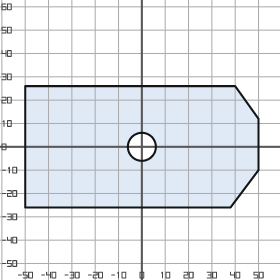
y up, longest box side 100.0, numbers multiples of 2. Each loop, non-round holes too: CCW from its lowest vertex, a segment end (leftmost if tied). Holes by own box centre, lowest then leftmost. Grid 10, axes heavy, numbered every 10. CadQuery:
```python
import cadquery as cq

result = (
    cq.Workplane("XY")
    .moveTo(-50.0, -26.0)
    .lineTo(38.0, -26.0)
    .lineTo(50.0, -10.0)
    .lineTo(50.0, 12.0)
    .lineTo(40.0, 26.0)
    .lineTo(-50.0, 26.0)
    .close()
    .moveTo(0.0, 0.0)
    .circle(6.0)
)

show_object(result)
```